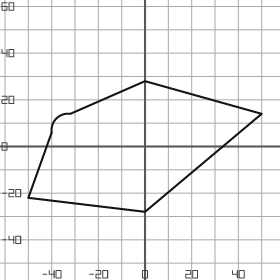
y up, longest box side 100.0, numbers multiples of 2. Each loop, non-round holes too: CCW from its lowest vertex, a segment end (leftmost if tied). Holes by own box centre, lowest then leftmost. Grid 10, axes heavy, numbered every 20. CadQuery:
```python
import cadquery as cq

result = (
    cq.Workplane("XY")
    .moveTo(0.0, -28.0)
    .lineTo(50.0, 14.0)
    .lineTo(0.0, 28.0)
    .lineTo(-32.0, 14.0)
    .threePointArc((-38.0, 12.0), (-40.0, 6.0))
    .lineTo(-50.0, -22.0)
    .close()
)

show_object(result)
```